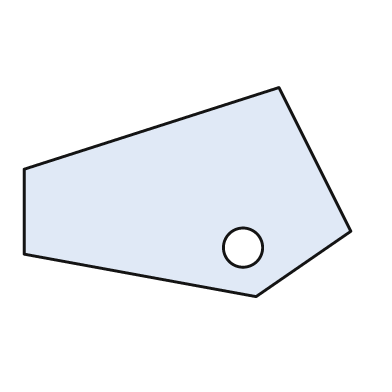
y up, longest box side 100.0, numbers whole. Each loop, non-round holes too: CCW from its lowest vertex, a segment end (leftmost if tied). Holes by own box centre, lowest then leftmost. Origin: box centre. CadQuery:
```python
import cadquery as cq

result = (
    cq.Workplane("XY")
    .moveTo(21.0, -32.0)
    .lineTo(50.0, -12.0)
    .lineTo(28.0, 32.0)
    .lineTo(-50.0, 7.0)
    .lineTo(-50.0, -19.0)
    .close()
    .moveTo(17.0, -17.0)
    .circle(6.0)
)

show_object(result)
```